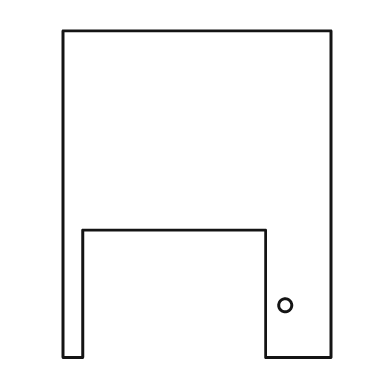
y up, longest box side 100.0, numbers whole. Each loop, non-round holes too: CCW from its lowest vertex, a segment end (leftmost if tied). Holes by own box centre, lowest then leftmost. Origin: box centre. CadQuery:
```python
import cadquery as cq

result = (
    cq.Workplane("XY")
    .moveTo(-41.0, -50.0)
    .lineTo(-35.0, -50.0)
    .lineTo(-35.0, -11.0)
    .lineTo(21.0, -11.0)
    .lineTo(21.0, -50.0)
    .lineTo(41.0, -50.0)
    .lineTo(41.0, 50.0)
    .lineTo(-41.0, 50.0)
    .close()
    .moveTo(27.0, -34.0)
    .circle(2.0)
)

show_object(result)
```